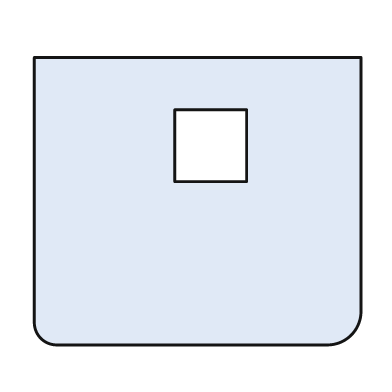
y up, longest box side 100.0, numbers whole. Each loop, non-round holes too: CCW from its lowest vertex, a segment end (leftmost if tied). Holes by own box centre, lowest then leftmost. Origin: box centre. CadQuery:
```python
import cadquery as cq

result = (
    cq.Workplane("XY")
    .moveTo(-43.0, -44.0)
    .lineTo(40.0, -44.0)
    .threePointArc((47.0, -41.0), (50.0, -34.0))
    .lineTo(50.0, 44.0)
    .lineTo(-50.0, 44.0)
    .lineTo(-50.0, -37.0)
    .threePointArc((-48.0, -42.0), (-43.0, -44.0))
    .close()
    .moveTo(-7.0, 6.0)
    .lineTo(15.0, 6.0)
    .lineTo(15.0, 28.0)
    .lineTo(-7.0, 28.0)
    .close()
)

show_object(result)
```